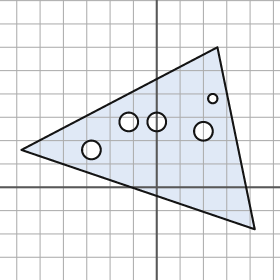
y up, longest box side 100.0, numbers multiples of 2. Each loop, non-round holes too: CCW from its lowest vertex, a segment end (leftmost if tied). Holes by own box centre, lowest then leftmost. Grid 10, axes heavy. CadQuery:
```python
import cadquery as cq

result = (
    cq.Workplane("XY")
    .moveTo(42.0, -18.0)
    .lineTo(26.0, 60.0)
    .lineTo(-58.0, 16.0)
    .close()
    .moveTo(-28.0, 16.0)
    .circle(4.0)
    .moveTo(20.0, 24.0)
    .circle(4.0)
    .moveTo(-12.0, 28.0)
    .circle(4.0)
    .moveTo(0.0, 28.0)
    .circle(4.0)
    .moveTo(24.0, 38.0)
    .circle(2.0)
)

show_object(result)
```